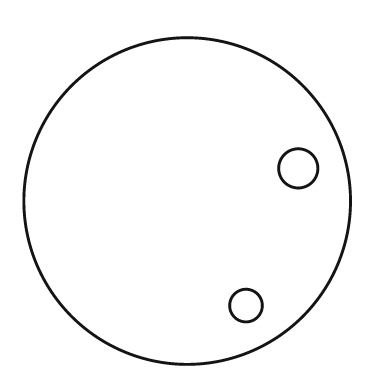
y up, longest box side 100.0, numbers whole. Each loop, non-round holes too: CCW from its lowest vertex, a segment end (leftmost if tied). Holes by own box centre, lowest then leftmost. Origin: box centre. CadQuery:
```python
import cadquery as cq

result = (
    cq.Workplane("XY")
    .moveTo(0.0, 0.0)
    .circle(50.0)
    .moveTo(18.0, -32.0)
    .circle(5.0)
    .moveTo(34.0, 10.0)
    .circle(6.0)
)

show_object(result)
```